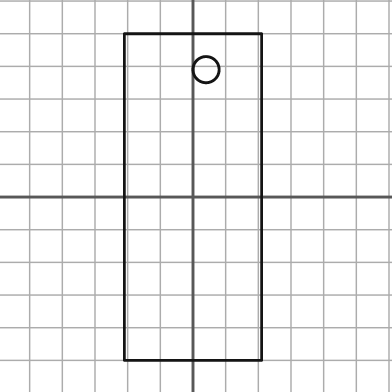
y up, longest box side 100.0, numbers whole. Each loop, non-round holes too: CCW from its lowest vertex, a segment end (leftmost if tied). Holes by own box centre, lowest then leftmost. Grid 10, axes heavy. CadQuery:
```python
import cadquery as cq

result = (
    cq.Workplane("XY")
    .moveTo(-21.0, -50.0)
    .lineTo(21.0, -50.0)
    .lineTo(21.0, 50.0)
    .lineTo(-21.0, 50.0)
    .close()
    .moveTo(4.0, 39.0)
    .circle(4.0)
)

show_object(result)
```